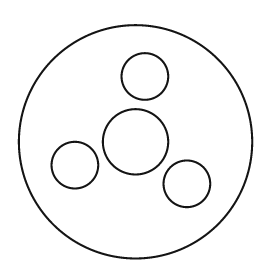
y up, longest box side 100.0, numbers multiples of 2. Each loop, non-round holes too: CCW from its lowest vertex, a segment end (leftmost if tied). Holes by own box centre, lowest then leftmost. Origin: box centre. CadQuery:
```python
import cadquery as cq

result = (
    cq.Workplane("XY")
    .moveTo(0.0, 0.0)
    .circle(50.0)
    .moveTo(22.0, -18.0)
    .circle(10.0)
    .moveTo(-26.0, -10.0)
    .circle(10.0)
    .moveTo(0.0, 0.0)
    .circle(14.0)
    .moveTo(4.0, 28.0)
    .circle(10.0)
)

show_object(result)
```